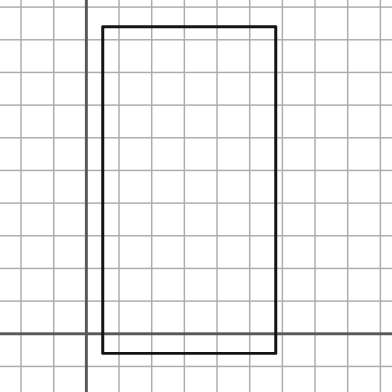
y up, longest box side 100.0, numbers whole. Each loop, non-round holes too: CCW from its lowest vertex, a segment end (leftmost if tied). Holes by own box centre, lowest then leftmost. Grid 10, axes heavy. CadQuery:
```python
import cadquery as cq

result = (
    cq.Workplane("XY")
    .moveTo(5.0, -6.0)
    .lineTo(58.0, -6.0)
    .lineTo(58.0, 94.0)
    .lineTo(5.0, 94.0)
    .close()
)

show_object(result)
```